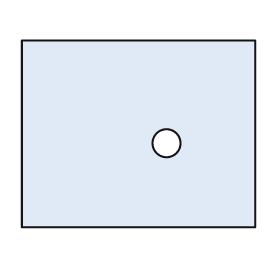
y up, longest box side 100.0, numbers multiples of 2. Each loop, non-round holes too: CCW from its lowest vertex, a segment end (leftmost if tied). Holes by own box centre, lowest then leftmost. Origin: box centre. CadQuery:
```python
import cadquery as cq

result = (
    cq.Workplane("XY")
    .moveTo(-50.0, -40.0)
    .lineTo(50.0, -40.0)
    .lineTo(50.0, 40.0)
    .lineTo(-50.0, 40.0)
    .close()
    .moveTo(12.0, -4.0)
    .circle(6.0)
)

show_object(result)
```